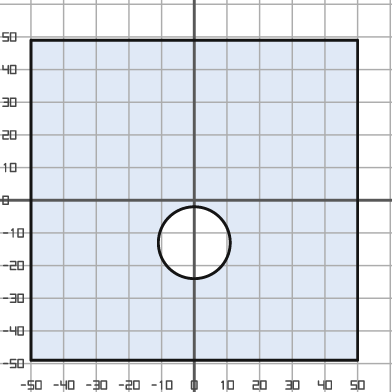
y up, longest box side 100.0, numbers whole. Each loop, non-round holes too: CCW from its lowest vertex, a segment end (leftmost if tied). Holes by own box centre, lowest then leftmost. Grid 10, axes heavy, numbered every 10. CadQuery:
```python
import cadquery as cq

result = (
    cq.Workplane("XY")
    .moveTo(-50.0, -49.0)
    .lineTo(50.0, -49.0)
    .lineTo(50.0, 49.0)
    .lineTo(-50.0, 49.0)
    .close()
    .moveTo(0.0, -13.0)
    .circle(11.0)
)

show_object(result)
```